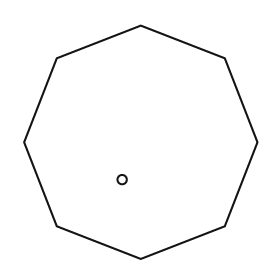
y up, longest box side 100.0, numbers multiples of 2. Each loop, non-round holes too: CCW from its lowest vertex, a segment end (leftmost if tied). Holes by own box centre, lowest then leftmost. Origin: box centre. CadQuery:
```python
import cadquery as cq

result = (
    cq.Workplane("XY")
    .moveTo(0.0, -50.0)
    .lineTo(36.0, -36.0)
    .lineTo(50.0, 0.0)
    .lineTo(36.0, 36.0)
    .lineTo(0.0, 50.0)
    .lineTo(-36.0, 36.0)
    .lineTo(-50.0, 0.0)
    .lineTo(-36.0, -36.0)
    .close()
    .moveTo(-8.0, -16.0)
    .circle(2.0)
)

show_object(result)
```